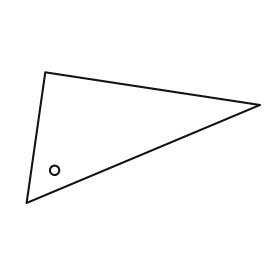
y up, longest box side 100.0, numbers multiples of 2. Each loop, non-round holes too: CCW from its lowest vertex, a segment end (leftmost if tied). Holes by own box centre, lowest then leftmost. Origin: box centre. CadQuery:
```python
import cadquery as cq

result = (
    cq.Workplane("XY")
    .moveTo(-50.0, -28.0)
    .lineTo(50.0, 14.0)
    .lineTo(-42.0, 28.0)
    .close()
    .moveTo(-38.0, -14.0)
    .circle(2.0)
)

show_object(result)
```